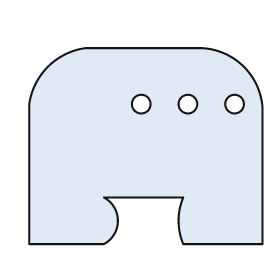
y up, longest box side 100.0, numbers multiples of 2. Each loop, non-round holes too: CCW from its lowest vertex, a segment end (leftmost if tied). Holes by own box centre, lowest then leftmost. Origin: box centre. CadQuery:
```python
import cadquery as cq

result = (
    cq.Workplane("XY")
    .moveTo(-50.0, -42.0)
    .lineTo(-18.0, -42.0)
    .threePointArc((-12.0, -32.0), (-18.0, -22.0))
    .lineTo(16.0, -22.0)
    .threePointArc((14.0, -32.0), (16.0, -42.0))
    .lineTo(50.0, -42.0)
    .lineTo(50.0, 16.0)
    .threePointArc((42.0, 34.0), (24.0, 42.0))
    .lineTo(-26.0, 42.0)
    .threePointArc((-42.0, 34.0), (-50.0, 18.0))
    .close()
    .moveTo(-2.0, 18.0)
    .circle(4.0)
    .moveTo(18.0, 18.0)
    .circle(4.0)
    .moveTo(38.0, 18.0)
    .circle(4.0)
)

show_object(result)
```